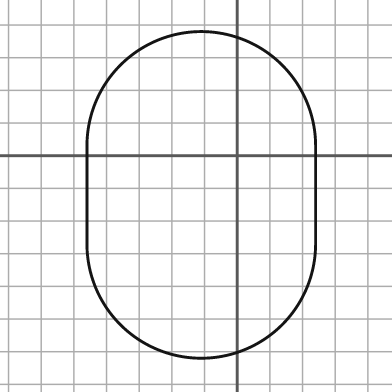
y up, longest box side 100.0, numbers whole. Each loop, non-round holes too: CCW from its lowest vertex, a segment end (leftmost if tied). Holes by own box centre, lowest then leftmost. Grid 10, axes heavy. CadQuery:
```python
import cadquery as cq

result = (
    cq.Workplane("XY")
    .moveTo(-46.0, -27.0)
    .threePointArc((-11.0, -62.0), (24.0, -27.0))
    .lineTo(24.0, 3.0)
    .threePointArc((-11.0, 38.0), (-46.0, 3.0))
    .close()
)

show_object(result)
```